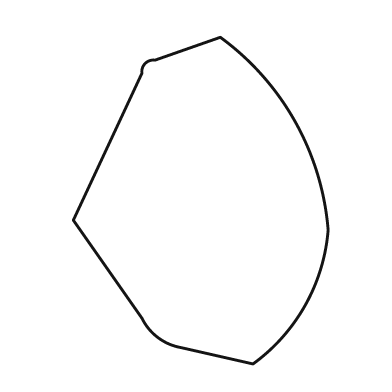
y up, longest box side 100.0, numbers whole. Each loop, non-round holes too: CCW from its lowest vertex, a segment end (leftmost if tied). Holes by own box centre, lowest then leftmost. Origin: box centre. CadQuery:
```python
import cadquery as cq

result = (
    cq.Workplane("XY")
    .moveTo(16.0, -50.0)
    .threePointArc((32.0, -32.0), (39.0, -9.0))
    .threePointArc((29.0, 24.0), (6.0, 50.0))
    .lineTo(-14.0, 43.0)
    .threePointArc((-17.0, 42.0), (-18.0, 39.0))
    .lineTo(-39.0, -6.0)
    .lineTo(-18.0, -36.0)
    .threePointArc((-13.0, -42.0), (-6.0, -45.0))
    .close()
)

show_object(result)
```